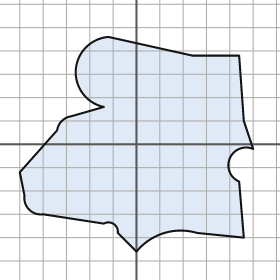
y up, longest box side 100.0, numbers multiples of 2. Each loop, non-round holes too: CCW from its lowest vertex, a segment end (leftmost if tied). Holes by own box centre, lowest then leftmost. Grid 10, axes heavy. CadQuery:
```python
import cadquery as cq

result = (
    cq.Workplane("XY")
    .moveTo(0.0, -46.0)
    .threePointArc((12.0, -38.0), (26.0, -38.0))
    .lineTo(46.0, -40.0)
    .lineTo(44.0, -16.0)
    .threePointArc((40.0, -6.0), (50.0, -2.0))
    .lineTo(46.0, 10.0)
    .lineTo(44.0, 38.0)
    .lineTo(24.0, 38.0)
    .lineTo(-12.0, 46.0)
    .threePointArc((-26.0, 32.0), (-14.0, 16.0))
    .lineTo(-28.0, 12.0)
    .threePointArc((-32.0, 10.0), (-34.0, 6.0))
    .lineTo(-50.0, -12.0)
    .lineTo(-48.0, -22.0)
    .threePointArc((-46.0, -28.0), (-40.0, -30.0))
    .lineTo(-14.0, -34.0)
    .threePointArc((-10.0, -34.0), (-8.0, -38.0))
    .close()
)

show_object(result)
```